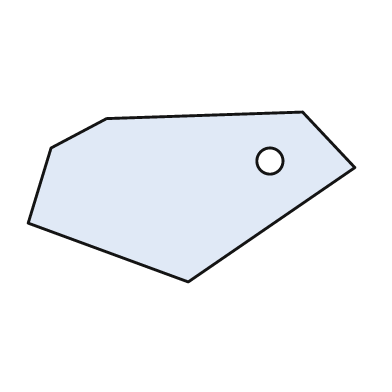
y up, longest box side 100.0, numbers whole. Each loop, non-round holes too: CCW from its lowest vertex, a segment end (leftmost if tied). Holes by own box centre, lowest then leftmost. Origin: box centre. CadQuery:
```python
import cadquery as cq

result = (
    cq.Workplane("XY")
    .moveTo(-1.0, -26.0)
    .lineTo(50.0, 9.0)
    .lineTo(34.0, 26.0)
    .lineTo(-26.0, 24.0)
    .lineTo(-43.0, 15.0)
    .lineTo(-50.0, -8.0)
    .close()
    .moveTo(24.0, 11.0)
    .circle(4.0)
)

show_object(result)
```